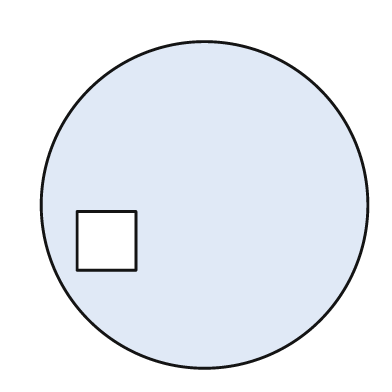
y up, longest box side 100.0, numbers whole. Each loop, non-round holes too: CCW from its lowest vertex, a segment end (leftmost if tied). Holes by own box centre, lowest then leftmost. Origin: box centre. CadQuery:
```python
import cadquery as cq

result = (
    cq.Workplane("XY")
    .moveTo(0.0, 0.0)
    .circle(50.0)
    .moveTo(-39.0, -20.0)
    .lineTo(-21.0, -20.0)
    .lineTo(-21.0, -2.0)
    .lineTo(-39.0, -2.0)
    .close()
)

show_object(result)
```